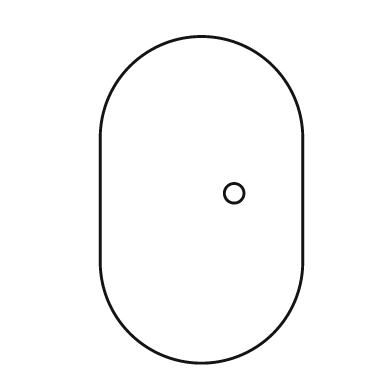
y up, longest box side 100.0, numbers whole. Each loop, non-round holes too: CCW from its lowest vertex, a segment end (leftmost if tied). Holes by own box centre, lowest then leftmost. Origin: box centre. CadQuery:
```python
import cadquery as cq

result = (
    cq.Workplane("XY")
    .moveTo(-31.0, -19.0)
    .threePointArc((0.0, -50.0), (31.0, -19.0))
    .lineTo(31.0, 19.0)
    .threePointArc((0.0, 50.0), (-31.0, 19.0))
    .close()
    .moveTo(10.0, 2.0)
    .circle(3.0)
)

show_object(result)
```